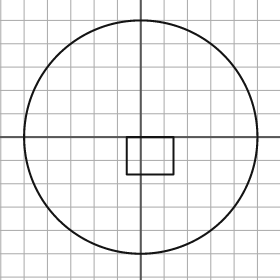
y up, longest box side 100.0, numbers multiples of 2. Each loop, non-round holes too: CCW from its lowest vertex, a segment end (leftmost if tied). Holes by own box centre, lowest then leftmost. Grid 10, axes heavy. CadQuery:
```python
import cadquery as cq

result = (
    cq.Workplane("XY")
    .moveTo(0.0, 0.0)
    .circle(50.0)
    .moveTo(-6.0, -16.0)
    .lineTo(14.0, -16.0)
    .lineTo(14.0, 0.0)
    .lineTo(-6.0, 0.0)
    .close()
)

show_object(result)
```